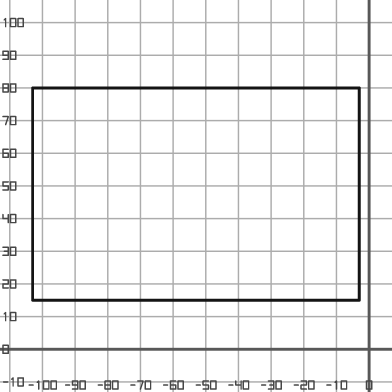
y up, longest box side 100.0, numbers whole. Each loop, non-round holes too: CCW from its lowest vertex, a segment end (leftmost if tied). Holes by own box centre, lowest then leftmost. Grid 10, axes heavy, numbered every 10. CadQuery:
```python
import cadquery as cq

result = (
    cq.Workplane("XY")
    .moveTo(-103.0, 15.0)
    .lineTo(-3.0, 15.0)
    .lineTo(-3.0, 80.0)
    .lineTo(-103.0, 80.0)
    .close()
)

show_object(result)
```